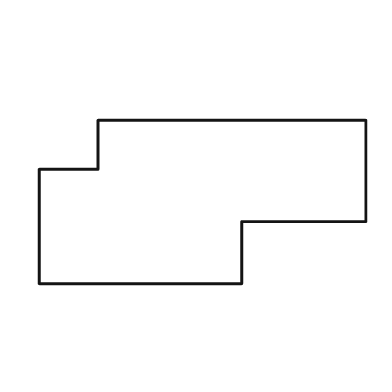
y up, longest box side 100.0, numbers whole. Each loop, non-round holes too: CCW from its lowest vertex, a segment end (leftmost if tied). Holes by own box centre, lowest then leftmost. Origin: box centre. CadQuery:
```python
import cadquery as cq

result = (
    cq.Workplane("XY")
    .moveTo(-50.0, -25.0)
    .lineTo(12.0, -25.0)
    .lineTo(12.0, -6.0)
    .lineTo(50.0, -6.0)
    .lineTo(50.0, 25.0)
    .lineTo(-32.0, 25.0)
    .lineTo(-32.0, 10.0)
    .lineTo(-50.0, 10.0)
    .close()
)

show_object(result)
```